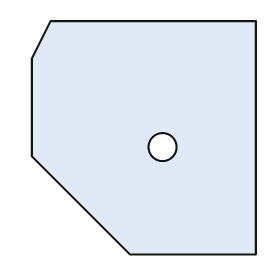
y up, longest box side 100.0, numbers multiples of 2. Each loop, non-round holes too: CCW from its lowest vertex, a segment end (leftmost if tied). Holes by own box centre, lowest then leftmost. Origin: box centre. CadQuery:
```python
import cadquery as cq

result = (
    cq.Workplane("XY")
    .moveTo(-6.0, -50.0)
    .lineTo(48.0, -50.0)
    .lineTo(48.0, 50.0)
    .lineTo(-40.0, 50.0)
    .lineTo(-48.0, 34.0)
    .lineTo(-48.0, -8.0)
    .close()
    .moveTo(8.0, -4.0)
    .circle(6.0)
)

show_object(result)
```